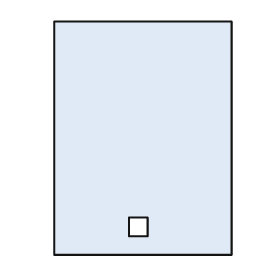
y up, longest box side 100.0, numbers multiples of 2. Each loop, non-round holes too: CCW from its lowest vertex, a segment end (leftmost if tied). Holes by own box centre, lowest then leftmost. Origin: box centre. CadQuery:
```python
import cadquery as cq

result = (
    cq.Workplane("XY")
    .moveTo(-38.0, -50.0)
    .lineTo(38.0, -50.0)
    .lineTo(38.0, 50.0)
    .lineTo(-38.0, 50.0)
    .close()
    .moveTo(-6.0, -42.0)
    .lineTo(2.0, -42.0)
    .lineTo(2.0, -34.0)
    .lineTo(-6.0, -34.0)
    .close()
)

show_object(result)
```